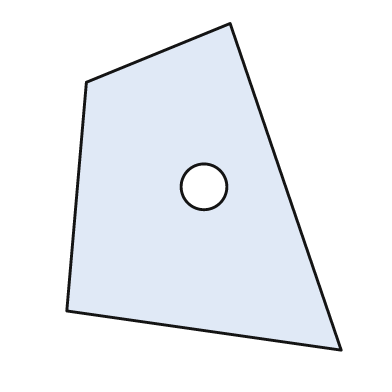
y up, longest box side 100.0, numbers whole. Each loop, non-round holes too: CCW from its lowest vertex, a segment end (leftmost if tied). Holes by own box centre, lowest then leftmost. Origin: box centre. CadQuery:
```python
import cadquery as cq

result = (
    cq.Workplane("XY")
    .moveTo(42.0, -50.0)
    .lineTo(8.0, 50.0)
    .lineTo(-36.0, 32.0)
    .lineTo(-42.0, -38.0)
    .close()
    .moveTo(0.0, 0.0)
    .circle(7.0)
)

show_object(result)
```